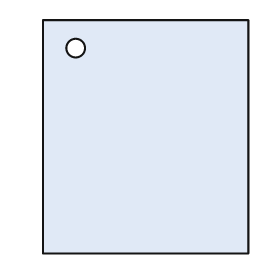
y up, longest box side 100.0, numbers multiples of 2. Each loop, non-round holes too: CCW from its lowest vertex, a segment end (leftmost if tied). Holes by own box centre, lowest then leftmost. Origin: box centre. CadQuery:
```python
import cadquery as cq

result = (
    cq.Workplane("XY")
    .moveTo(-44.0, -50.0)
    .lineTo(44.0, -50.0)
    .lineTo(44.0, 50.0)
    .lineTo(-44.0, 50.0)
    .close()
    .moveTo(-30.0, 38.0)
    .circle(4.0)
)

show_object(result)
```